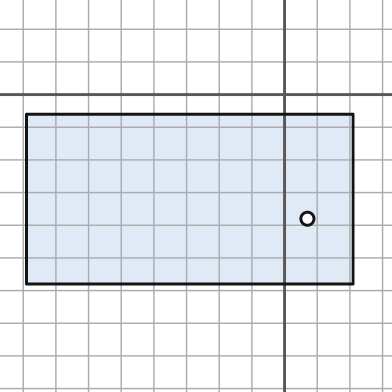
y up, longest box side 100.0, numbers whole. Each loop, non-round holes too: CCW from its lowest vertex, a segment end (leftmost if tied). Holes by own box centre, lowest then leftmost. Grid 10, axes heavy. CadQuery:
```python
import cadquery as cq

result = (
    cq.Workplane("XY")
    .moveTo(-79.0, -58.0)
    .lineTo(21.0, -58.0)
    .lineTo(21.0, -6.0)
    .lineTo(-79.0, -6.0)
    .close()
    .moveTo(7.0, -38.0)
    .circle(2.0)
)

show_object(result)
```